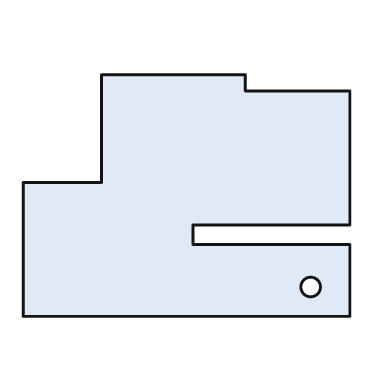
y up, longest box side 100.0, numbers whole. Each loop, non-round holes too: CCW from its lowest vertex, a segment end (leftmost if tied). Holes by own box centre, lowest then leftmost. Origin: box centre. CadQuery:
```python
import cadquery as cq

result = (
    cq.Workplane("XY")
    .moveTo(-50.0, -37.0)
    .lineTo(50.0, -37.0)
    .lineTo(50.0, -15.0)
    .lineTo(2.0, -15.0)
    .lineTo(2.0, -9.0)
    .lineTo(50.0, -9.0)
    .lineTo(50.0, 32.0)
    .lineTo(18.0, 32.0)
    .lineTo(18.0, 37.0)
    .lineTo(-26.0, 37.0)
    .lineTo(-26.0, 4.0)
    .lineTo(-50.0, 4.0)
    .close()
    .moveTo(38.0, -28.0)
    .circle(3.0)
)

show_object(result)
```